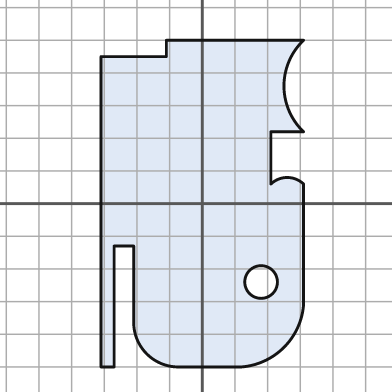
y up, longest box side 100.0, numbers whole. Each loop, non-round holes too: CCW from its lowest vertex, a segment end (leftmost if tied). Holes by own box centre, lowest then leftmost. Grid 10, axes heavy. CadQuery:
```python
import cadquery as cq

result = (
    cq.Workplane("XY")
    .moveTo(-31.0, -50.0)
    .lineTo(-27.0, -50.0)
    .lineTo(-27.0, -13.0)
    .lineTo(-21.0, -13.0)
    .lineTo(-21.0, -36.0)
    .threePointArc((-17.0, -46.0), (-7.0, -50.0))
    .lineTo(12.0, -50.0)
    .threePointArc((25.0, -44.0), (31.0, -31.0))
    .lineTo(31.0, 6.0)
    .threePointArc((26.0, 8.0), (21.0, 6.0))
    .lineTo(21.0, 22.0)
    .lineTo(31.0, 22.0)
    .threePointArc((25.0, 36.0), (31.0, 50.0))
    .lineTo(-11.0, 50.0)
    .lineTo(-11.0, 45.0)
    .lineTo(-31.0, 45.0)
    .close()
    .moveTo(18.0, -24.0)
    .circle(5.0)
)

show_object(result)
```